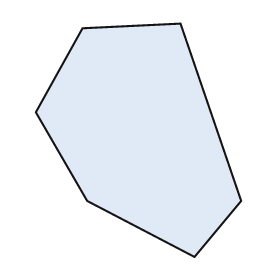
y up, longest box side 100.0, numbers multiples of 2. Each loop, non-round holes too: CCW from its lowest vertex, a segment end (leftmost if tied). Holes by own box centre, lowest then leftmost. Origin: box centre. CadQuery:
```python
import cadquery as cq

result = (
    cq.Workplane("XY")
    .moveTo(24.0, -50.0)
    .lineTo(44.0, -26.0)
    .lineTo(18.0, 50.0)
    .lineTo(-24.0, 48.0)
    .lineTo(-44.0, 12.0)
    .lineTo(-22.0, -26.0)
    .close()
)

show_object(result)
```